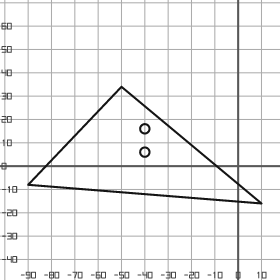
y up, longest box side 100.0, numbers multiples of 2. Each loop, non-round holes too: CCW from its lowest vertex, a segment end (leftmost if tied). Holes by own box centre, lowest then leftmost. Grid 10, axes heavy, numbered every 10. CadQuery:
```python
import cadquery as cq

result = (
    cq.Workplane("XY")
    .moveTo(10.0, -16.0)
    .lineTo(-50.0, 34.0)
    .lineTo(-90.0, -8.0)
    .close()
    .moveTo(-40.0, 6.0)
    .circle(2.0)
    .moveTo(-40.0, 16.0)
    .circle(2.0)
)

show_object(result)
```